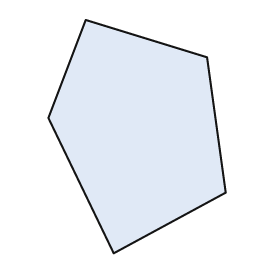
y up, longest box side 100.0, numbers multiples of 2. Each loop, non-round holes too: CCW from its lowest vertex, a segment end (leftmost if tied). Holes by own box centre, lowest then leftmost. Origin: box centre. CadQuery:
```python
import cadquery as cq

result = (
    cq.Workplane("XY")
    .moveTo(-10.0, -50.0)
    .lineTo(38.0, -24.0)
    .lineTo(30.0, 34.0)
    .lineTo(-22.0, 50.0)
    .lineTo(-38.0, 8.0)
    .close()
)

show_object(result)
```